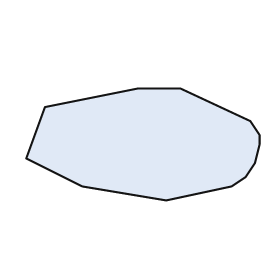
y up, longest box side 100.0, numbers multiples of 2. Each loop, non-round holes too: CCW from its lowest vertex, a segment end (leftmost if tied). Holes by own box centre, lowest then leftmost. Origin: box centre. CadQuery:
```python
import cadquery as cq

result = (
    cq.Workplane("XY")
    .moveTo(10.0, -24.0)
    .lineTo(38.0, -18.0)
    .lineTo(44.0, -14.0)
    .lineTo(48.0, -8.0)
    .lineTo(50.0, 0.0)
    .lineTo(50.0, 4.0)
    .lineTo(46.0, 10.0)
    .lineTo(16.0, 24.0)
    .lineTo(-2.0, 24.0)
    .lineTo(-42.0, 16.0)
    .lineTo(-50.0, -6.0)
    .lineTo(-26.0, -18.0)
    .close()
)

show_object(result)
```